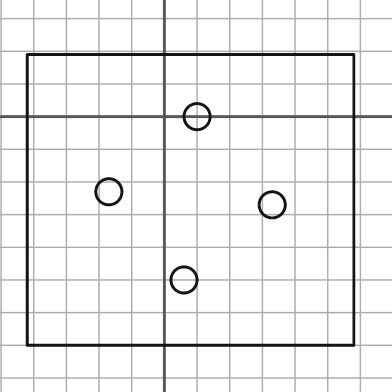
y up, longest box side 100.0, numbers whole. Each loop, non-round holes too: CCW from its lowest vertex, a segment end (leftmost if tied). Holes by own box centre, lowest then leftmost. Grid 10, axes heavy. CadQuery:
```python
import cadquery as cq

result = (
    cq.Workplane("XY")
    .moveTo(-42.0, -70.0)
    .lineTo(58.0, -70.0)
    .lineTo(58.0, 19.0)
    .lineTo(-42.0, 19.0)
    .close()
    .moveTo(6.0, -50.0)
    .circle(4.0)
    .moveTo(33.0, -27.0)
    .circle(4.0)
    .moveTo(-17.0, -23.0)
    .circle(4.0)
    .moveTo(10.0, 0.0)
    .circle(4.0)
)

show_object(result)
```